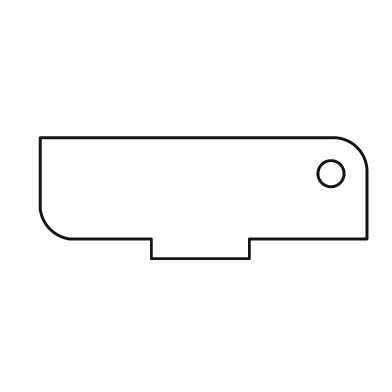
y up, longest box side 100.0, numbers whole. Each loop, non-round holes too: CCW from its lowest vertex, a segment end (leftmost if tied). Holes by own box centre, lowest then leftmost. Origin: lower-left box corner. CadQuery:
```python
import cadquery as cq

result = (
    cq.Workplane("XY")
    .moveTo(34.0, 0.0)
    .lineTo(64.0, 0.0)
    .lineTo(64.0, 6.0)
    .lineTo(100.0, 6.0)
    .lineTo(100.0, 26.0)
    .threePointArc((97.0, 34.0), (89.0, 37.0))
    .lineTo(0.0, 37.0)
    .lineTo(0.0, 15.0)
    .threePointArc((3.0, 9.0), (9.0, 6.0))
    .lineTo(34.0, 6.0)
    .close()
    .moveTo(89.0, 26.0)
    .circle(4.0)
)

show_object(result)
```